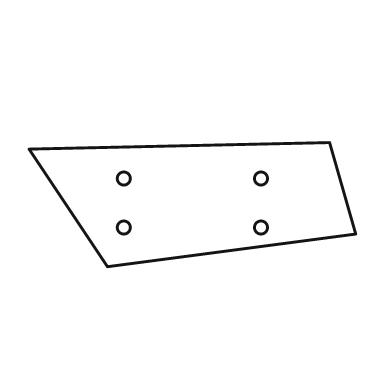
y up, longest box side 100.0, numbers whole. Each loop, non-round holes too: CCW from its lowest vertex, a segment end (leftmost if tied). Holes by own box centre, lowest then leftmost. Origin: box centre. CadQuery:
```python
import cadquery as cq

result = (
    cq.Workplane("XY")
    .moveTo(-26.0, -19.0)
    .lineTo(50.0, -9.0)
    .lineTo(42.0, 19.0)
    .lineTo(-50.0, 17.0)
    .close()
    .moveTo(-21.0, -7.0)
    .circle(2.0)
    .moveTo(21.0, -7.0)
    .circle(2.0)
    .moveTo(-21.0, 8.0)
    .circle(2.0)
    .moveTo(21.0, 8.0)
    .circle(2.0)
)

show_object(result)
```